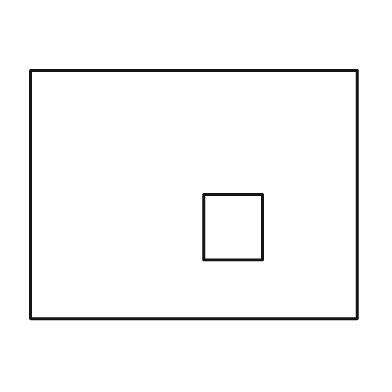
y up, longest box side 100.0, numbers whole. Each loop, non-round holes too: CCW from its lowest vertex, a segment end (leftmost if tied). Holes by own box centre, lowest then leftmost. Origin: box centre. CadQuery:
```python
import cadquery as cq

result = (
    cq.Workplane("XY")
    .moveTo(-50.0, -38.0)
    .lineTo(50.0, -38.0)
    .lineTo(50.0, 38.0)
    .lineTo(-50.0, 38.0)
    .close()
    .moveTo(3.0, -20.0)
    .lineTo(21.0, -20.0)
    .lineTo(21.0, 0.0)
    .lineTo(3.0, 0.0)
    .close()
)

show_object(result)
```